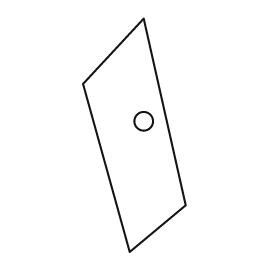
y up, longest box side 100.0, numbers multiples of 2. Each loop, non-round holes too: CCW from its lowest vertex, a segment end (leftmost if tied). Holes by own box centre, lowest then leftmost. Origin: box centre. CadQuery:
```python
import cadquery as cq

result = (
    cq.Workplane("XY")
    .moveTo(-2.0, -50.0)
    .lineTo(22.0, -30.0)
    .lineTo(4.0, 50.0)
    .lineTo(-22.0, 22.0)
    .close()
    .moveTo(4.0, 6.0)
    .circle(4.0)
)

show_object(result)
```